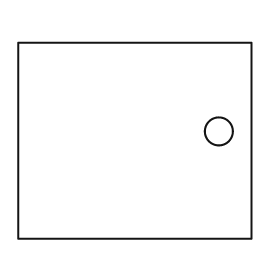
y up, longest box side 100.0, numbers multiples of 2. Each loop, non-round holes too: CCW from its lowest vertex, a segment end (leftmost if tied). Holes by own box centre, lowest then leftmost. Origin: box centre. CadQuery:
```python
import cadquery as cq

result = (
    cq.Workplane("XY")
    .moveTo(-50.0, -42.0)
    .lineTo(50.0, -42.0)
    .lineTo(50.0, 42.0)
    .lineTo(-50.0, 42.0)
    .close()
    .moveTo(36.0, 4.0)
    .circle(6.0)
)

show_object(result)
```